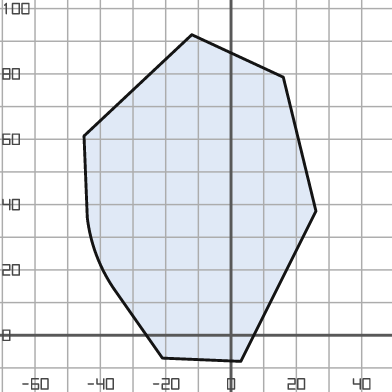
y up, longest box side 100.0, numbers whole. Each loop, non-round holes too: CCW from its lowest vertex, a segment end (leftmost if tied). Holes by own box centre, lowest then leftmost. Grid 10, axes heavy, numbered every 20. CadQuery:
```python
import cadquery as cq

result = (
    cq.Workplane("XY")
    .moveTo(3.0, -8.0)
    .lineTo(26.0, 38.0)
    .lineTo(16.0, 79.0)
    .lineTo(-12.0, 92.0)
    .lineTo(-45.0, 61.0)
    .lineTo(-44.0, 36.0)
    .threePointArc((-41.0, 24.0), (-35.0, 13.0))
    .lineTo(-21.0, -7.0)
    .close()
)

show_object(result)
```